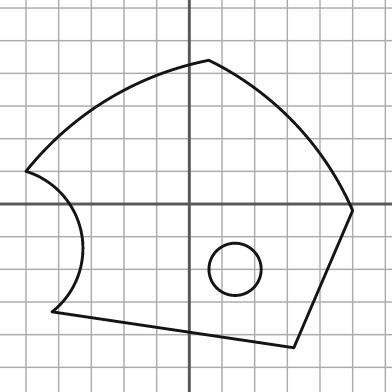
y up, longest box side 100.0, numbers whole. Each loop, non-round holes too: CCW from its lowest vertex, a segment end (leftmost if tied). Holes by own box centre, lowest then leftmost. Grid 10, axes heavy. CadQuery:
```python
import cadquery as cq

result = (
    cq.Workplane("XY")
    .moveTo(32.0, -44.0)
    .lineTo(50.0, -2.0)
    .threePointArc((32.0, 25.0), (6.0, 44.0))
    .threePointArc((-25.0, 32.0), (-50.0, 10.0))
    .threePointArc((-33.0, -9.0), (-42.0, -33.0))
    .close()
    .moveTo(14.0, -20.0)
    .circle(8.0)
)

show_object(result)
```